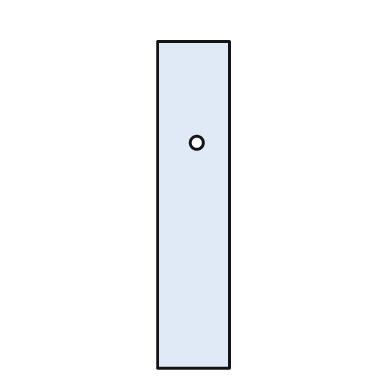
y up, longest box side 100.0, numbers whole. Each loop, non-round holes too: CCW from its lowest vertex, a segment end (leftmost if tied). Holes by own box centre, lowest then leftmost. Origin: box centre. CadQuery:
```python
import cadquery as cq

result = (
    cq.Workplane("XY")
    .moveTo(-11.0, -50.0)
    .lineTo(11.0, -50.0)
    .lineTo(11.0, 50.0)
    .lineTo(-11.0, 50.0)
    .close()
    .moveTo(1.0, 19.0)
    .circle(2.0)
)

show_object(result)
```